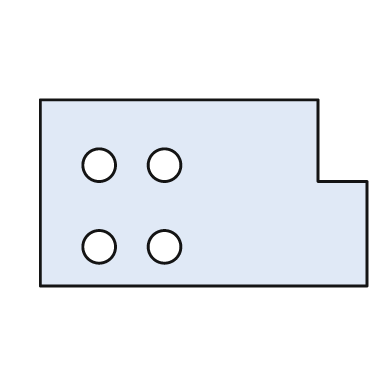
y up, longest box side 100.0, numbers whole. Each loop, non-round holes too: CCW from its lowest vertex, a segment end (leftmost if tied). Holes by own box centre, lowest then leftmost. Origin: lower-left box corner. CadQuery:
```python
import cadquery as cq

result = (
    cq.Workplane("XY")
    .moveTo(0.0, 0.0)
    .lineTo(100.0, 0.0)
    .lineTo(100.0, 32.0)
    .lineTo(85.0, 32.0)
    .lineTo(85.0, 57.0)
    .lineTo(0.0, 57.0)
    .close()
    .moveTo(18.0, 12.0)
    .circle(5.0)
    .moveTo(38.0, 12.0)
    .circle(5.0)
    .moveTo(18.0, 37.0)
    .circle(5.0)
    .moveTo(38.0, 37.0)
    .circle(5.0)
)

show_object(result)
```